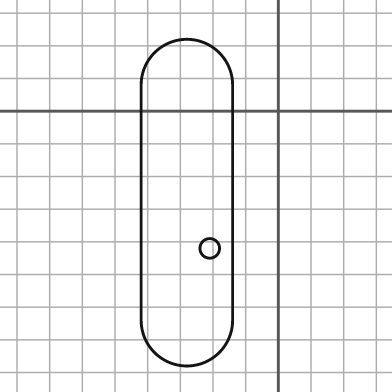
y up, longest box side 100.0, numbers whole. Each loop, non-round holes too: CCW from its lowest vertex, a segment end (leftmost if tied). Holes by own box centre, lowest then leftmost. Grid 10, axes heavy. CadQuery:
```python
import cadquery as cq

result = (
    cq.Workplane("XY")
    .moveTo(-42.0, -64.0)
    .threePointArc((-28.0, -78.0), (-14.0, -64.0))
    .lineTo(-14.0, 8.0)
    .threePointArc((-28.0, 22.0), (-42.0, 8.0))
    .close()
    .moveTo(-21.0, -42.0)
    .circle(3.0)
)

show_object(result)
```